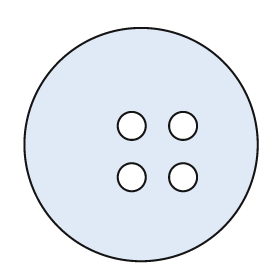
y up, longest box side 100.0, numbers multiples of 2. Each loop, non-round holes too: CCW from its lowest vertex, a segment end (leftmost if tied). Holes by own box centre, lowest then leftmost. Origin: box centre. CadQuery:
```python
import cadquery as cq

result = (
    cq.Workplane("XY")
    .moveTo(0.0, 0.0)
    .circle(50.0)
    .moveTo(-4.0, -14.0)
    .circle(6.0)
    .moveTo(18.0, -14.0)
    .circle(6.0)
    .moveTo(-4.0, 8.0)
    .circle(6.0)
    .moveTo(18.0, 8.0)
    .circle(6.0)
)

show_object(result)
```